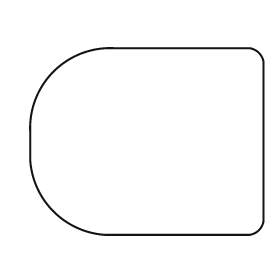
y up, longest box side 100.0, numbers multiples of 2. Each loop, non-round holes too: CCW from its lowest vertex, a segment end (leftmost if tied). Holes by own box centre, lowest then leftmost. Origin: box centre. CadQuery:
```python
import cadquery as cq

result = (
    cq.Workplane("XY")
    .moveTo(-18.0, -40.0)
    .lineTo(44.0, -40.0)
    .threePointArc((48.0, -38.0), (50.0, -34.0))
    .lineTo(50.0, 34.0)
    .threePointArc((48.0, 38.0), (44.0, 40.0))
    .lineTo(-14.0, 40.0)
    .threePointArc((-40.0, 30.0), (-50.0, 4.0))
    .lineTo(-50.0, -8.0)
    .threePointArc((-40.0, -30.0), (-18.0, -40.0))
    .close()
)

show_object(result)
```